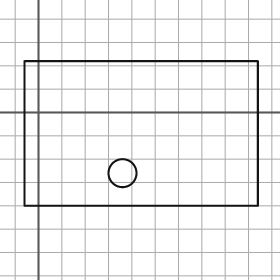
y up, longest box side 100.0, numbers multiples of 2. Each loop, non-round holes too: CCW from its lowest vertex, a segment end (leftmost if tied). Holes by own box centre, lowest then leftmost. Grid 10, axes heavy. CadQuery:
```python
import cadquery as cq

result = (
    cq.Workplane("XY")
    .moveTo(-6.0, -40.0)
    .lineTo(94.0, -40.0)
    .lineTo(94.0, 22.0)
    .lineTo(-6.0, 22.0)
    .close()
    .moveTo(36.0, -26.0)
    .circle(6.0)
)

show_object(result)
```